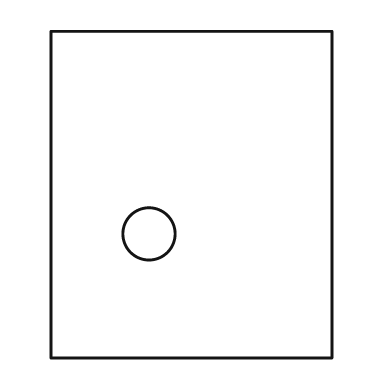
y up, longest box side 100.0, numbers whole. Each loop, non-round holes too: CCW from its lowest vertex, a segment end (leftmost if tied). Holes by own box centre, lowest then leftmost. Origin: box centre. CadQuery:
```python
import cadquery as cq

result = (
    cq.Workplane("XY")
    .moveTo(-43.0, -50.0)
    .lineTo(43.0, -50.0)
    .lineTo(43.0, 50.0)
    .lineTo(-43.0, 50.0)
    .close()
    .moveTo(-13.0, -12.0)
    .circle(8.0)
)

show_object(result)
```